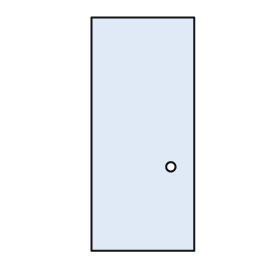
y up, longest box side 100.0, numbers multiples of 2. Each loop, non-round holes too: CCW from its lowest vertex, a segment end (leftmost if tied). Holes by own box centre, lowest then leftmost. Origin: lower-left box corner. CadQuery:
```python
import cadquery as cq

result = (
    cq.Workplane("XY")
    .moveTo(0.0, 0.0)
    .lineTo(44.0, 0.0)
    .lineTo(44.0, 100.0)
    .lineTo(0.0, 100.0)
    .close()
    .moveTo(34.0, 36.0)
    .circle(2.0)
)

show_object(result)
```